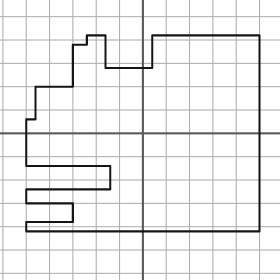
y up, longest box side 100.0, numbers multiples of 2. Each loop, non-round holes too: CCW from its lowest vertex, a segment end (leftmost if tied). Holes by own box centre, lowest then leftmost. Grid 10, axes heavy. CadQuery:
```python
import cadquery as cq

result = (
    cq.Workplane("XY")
    .moveTo(-50.0, -42.0)
    .lineTo(50.0, -42.0)
    .lineTo(50.0, 42.0)
    .lineTo(4.0, 42.0)
    .lineTo(4.0, 28.0)
    .lineTo(-16.0, 28.0)
    .lineTo(-16.0, 42.0)
    .lineTo(-24.0, 42.0)
    .lineTo(-24.0, 38.0)
    .lineTo(-30.0, 38.0)
    .lineTo(-30.0, 20.0)
    .lineTo(-46.0, 20.0)
    .lineTo(-46.0, 6.0)
    .lineTo(-50.0, 6.0)
    .lineTo(-50.0, -14.0)
    .lineTo(-14.0, -14.0)
    .lineTo(-14.0, -24.0)
    .lineTo(-50.0, -24.0)
    .lineTo(-50.0, -30.0)
    .lineTo(-30.0, -30.0)
    .lineTo(-30.0, -38.0)
    .lineTo(-50.0, -38.0)
    .close()
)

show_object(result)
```